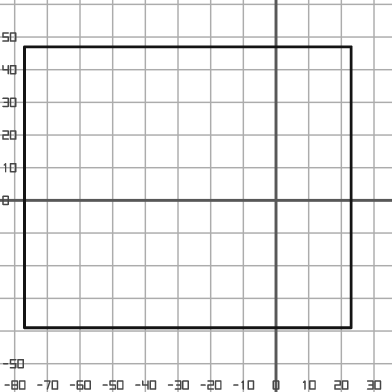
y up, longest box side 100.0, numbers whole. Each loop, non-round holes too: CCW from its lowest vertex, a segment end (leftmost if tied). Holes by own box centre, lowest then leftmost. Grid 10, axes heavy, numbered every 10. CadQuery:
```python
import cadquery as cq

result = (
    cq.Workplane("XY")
    .moveTo(-77.0, -39.0)
    .lineTo(23.0, -39.0)
    .lineTo(23.0, 47.0)
    .lineTo(-77.0, 47.0)
    .close()
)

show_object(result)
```